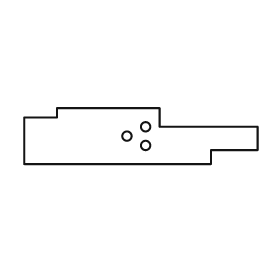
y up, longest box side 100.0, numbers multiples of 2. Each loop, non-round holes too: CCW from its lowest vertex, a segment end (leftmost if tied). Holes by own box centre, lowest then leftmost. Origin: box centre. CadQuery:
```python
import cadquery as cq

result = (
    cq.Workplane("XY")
    .moveTo(-50.0, -12.0)
    .lineTo(30.0, -12.0)
    .lineTo(30.0, -6.0)
    .lineTo(50.0, -6.0)
    .lineTo(50.0, 4.0)
    .lineTo(8.0, 4.0)
    .lineTo(8.0, 12.0)
    .lineTo(-36.0, 12.0)
    .lineTo(-36.0, 8.0)
    .lineTo(-50.0, 8.0)
    .close()
    .moveTo(2.0, -4.0)
    .circle(2.0)
    .moveTo(-6.0, 0.0)
    .circle(2.0)
    .moveTo(2.0, 4.0)
    .circle(2.0)
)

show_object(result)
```